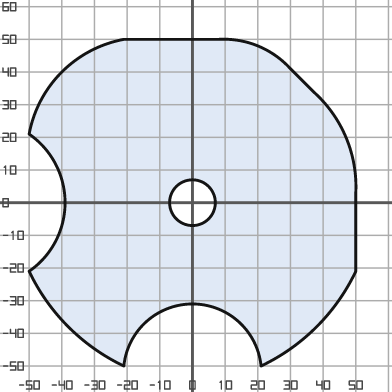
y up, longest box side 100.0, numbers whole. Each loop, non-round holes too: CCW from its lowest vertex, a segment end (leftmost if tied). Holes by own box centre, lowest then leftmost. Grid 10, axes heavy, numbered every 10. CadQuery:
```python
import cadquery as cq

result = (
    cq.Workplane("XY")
    .moveTo(-21.0, -50.0)
    .threePointArc((0.0, -31.0), (21.0, -50.0))
    .threePointArc((38.0, -38.0), (50.0, -21.0))
    .lineTo(50.0, 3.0)
    .threePointArc((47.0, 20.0), (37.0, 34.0))
    .lineTo(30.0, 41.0)
    .threePointArc((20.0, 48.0), (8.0, 50.0))
    .lineTo(-21.0, 50.0)
    .threePointArc((-40.0, 40.0), (-50.0, 21.0))
    .threePointArc((-39.0, 0.0), (-50.0, -21.0))
    .threePointArc((-38.0, -38.0), (-21.0, -50.0))
    .close()
    .moveTo(0.0, 0.0)
    .circle(7.0)
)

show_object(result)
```